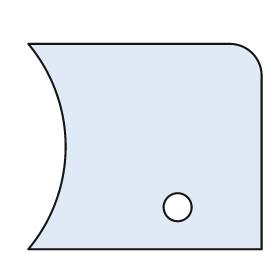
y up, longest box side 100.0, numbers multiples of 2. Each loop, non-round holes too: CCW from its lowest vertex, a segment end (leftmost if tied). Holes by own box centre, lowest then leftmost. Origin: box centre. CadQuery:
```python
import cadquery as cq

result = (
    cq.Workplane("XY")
    .moveTo(-50.0, -44.0)
    .lineTo(50.0, -44.0)
    .lineTo(50.0, 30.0)
    .threePointArc((46.0, 40.0), (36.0, 44.0))
    .lineTo(-50.0, 44.0)
    .threePointArc((-34.0, 0.0), (-50.0, -44.0))
    .close()
    .moveTo(14.0, -26.0)
    .circle(6.0)
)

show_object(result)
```